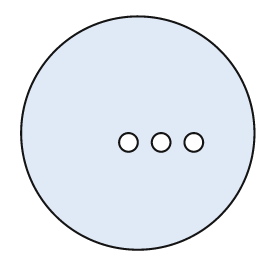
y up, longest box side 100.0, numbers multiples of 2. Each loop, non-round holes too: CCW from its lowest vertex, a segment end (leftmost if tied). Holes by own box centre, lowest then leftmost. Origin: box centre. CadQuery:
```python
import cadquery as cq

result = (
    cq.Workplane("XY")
    .moveTo(0.0, 0.0)
    .circle(50.0)
    .moveTo(-4.0, -4.0)
    .circle(4.0)
    .moveTo(10.0, -4.0)
    .circle(4.0)
    .moveTo(24.0, -4.0)
    .circle(4.0)
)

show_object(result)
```